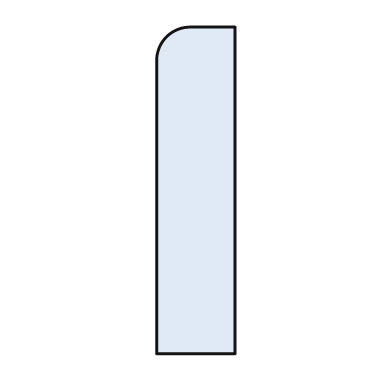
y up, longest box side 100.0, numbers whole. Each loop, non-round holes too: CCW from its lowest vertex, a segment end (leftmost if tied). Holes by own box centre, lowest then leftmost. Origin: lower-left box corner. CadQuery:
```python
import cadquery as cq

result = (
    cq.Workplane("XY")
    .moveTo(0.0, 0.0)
    .lineTo(24.0, 0.0)
    .lineTo(24.0, 100.0)
    .lineTo(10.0, 100.0)
    .threePointArc((3.0, 97.0), (0.0, 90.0))
    .close()
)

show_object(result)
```